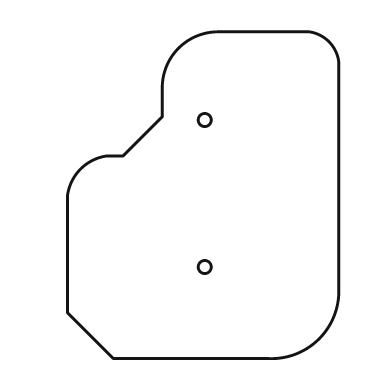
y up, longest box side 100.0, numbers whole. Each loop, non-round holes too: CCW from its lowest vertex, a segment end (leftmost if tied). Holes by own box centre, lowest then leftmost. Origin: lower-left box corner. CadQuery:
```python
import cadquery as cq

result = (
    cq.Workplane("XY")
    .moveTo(14.0, 0.0)
    .lineTo(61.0, 0.0)
    .threePointArc((77.0, 6.0), (83.0, 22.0))
    .lineTo(83.0, 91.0)
    .threePointArc((80.0, 97.0), (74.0, 100.0))
    .lineTo(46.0, 100.0)
    .threePointArc((34.0, 95.0), (29.0, 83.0))
    .lineTo(29.0, 74.0)
    .lineTo(17.0, 62.0)
    .lineTo(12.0, 62.0)
    .threePointArc((4.0, 58.0), (0.0, 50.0))
    .lineTo(0.0, 14.0)
    .close()
    .moveTo(42.0, 28.0)
    .circle(2.0)
    .moveTo(42.0, 73.0)
    .circle(2.0)
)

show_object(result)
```